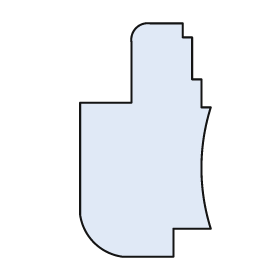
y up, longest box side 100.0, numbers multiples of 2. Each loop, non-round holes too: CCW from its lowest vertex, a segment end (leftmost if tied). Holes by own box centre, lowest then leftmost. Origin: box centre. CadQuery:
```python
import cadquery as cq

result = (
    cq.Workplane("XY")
    .moveTo(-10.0, -50.0)
    .lineTo(12.0, -50.0)
    .lineTo(12.0, -38.0)
    .lineTo(28.0, -38.0)
    .threePointArc((24.0, -12.0), (28.0, 14.0))
    .lineTo(24.0, 14.0)
    .lineTo(24.0, 26.0)
    .lineTo(20.0, 26.0)
    .lineTo(20.0, 44.0)
    .lineTo(16.0, 44.0)
    .lineTo(16.0, 50.0)
    .lineTo(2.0, 50.0)
    .threePointArc((-4.0, 48.0), (-6.0, 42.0))
    .lineTo(-6.0, 16.0)
    .lineTo(-28.0, 16.0)
    .lineTo(-28.0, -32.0)
    .threePointArc((-22.0, -44.0), (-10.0, -50.0))
    .close()
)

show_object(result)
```